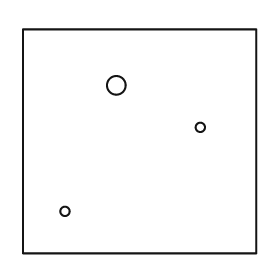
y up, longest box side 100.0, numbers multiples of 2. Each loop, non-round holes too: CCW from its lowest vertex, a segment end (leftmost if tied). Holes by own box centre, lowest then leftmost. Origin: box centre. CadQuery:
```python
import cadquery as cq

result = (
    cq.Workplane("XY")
    .moveTo(-50.0, -48.0)
    .lineTo(50.0, -48.0)
    .lineTo(50.0, 48.0)
    .lineTo(-50.0, 48.0)
    .close()
    .moveTo(-32.0, -30.0)
    .circle(2.0)
    .moveTo(26.0, 6.0)
    .circle(2.0)
    .moveTo(-10.0, 24.0)
    .circle(4.0)
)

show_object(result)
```